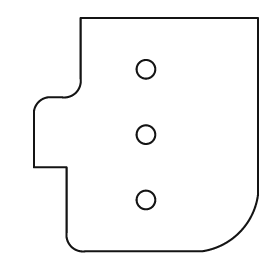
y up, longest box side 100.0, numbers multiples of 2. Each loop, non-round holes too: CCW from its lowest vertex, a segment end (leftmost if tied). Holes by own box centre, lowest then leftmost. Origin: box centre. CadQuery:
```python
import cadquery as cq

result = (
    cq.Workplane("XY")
    .moveTo(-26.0, -50.0)
    .lineTo(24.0, -50.0)
    .threePointArc((40.0, -42.0), (48.0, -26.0))
    .lineTo(48.0, 50.0)
    .lineTo(-28.0, 50.0)
    .lineTo(-28.0, 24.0)
    .threePointArc((-30.0, 18.0), (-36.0, 16.0))
    .lineTo(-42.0, 16.0)
    .threePointArc((-46.0, 14.0), (-48.0, 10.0))
    .lineTo(-48.0, -14.0)
    .lineTo(-34.0, -14.0)
    .lineTo(-34.0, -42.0)
    .threePointArc((-32.0, -48.0), (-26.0, -50.0))
    .close()
    .moveTo(0.0, -28.0)
    .circle(4.0)
    .moveTo(0.0, 0.0)
    .circle(4.0)
    .moveTo(0.0, 28.0)
    .circle(4.0)
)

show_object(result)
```